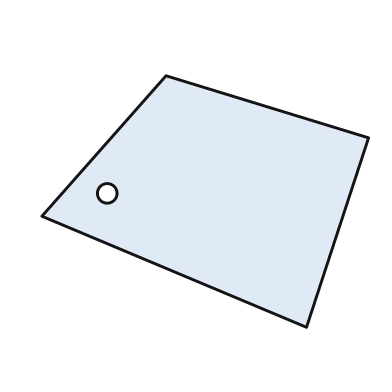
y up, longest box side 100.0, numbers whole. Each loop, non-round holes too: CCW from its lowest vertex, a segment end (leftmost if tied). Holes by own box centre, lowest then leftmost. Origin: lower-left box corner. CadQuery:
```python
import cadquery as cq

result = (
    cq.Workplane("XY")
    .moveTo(81.0, 0.0)
    .lineTo(100.0, 58.0)
    .lineTo(38.0, 77.0)
    .lineTo(0.0, 34.0)
    .close()
    .moveTo(20.0, 41.0)
    .circle(3.0)
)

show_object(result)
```